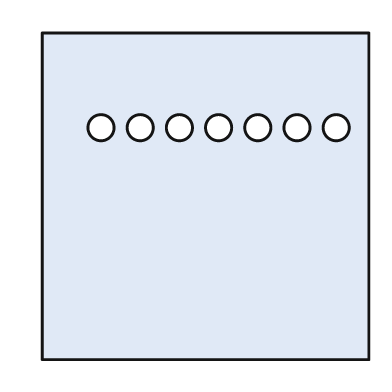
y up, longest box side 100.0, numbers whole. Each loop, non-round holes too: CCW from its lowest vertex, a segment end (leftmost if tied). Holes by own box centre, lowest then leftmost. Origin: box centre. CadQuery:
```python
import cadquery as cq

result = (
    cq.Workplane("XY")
    .moveTo(-50.0, -50.0)
    .lineTo(50.0, -50.0)
    .lineTo(50.0, 50.0)
    .lineTo(-50.0, 50.0)
    .close()
    .moveTo(-32.0, 21.0)
    .circle(4.0)
    .moveTo(-20.0, 21.0)
    .circle(4.0)
    .moveTo(-8.0, 21.0)
    .circle(4.0)
    .moveTo(4.0, 21.0)
    .circle(4.0)
    .moveTo(16.0, 21.0)
    .circle(4.0)
    .moveTo(28.0, 21.0)
    .circle(4.0)
    .moveTo(40.0, 21.0)
    .circle(4.0)
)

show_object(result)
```